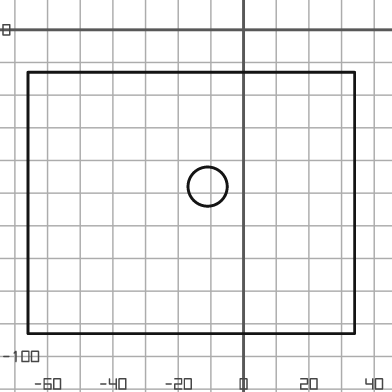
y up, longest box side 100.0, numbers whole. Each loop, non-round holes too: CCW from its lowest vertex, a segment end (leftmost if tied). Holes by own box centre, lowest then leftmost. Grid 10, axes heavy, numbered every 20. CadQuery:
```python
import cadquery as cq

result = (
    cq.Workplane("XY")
    .moveTo(-66.0, -93.0)
    .lineTo(34.0, -93.0)
    .lineTo(34.0, -13.0)
    .lineTo(-66.0, -13.0)
    .close()
    .moveTo(-11.0, -48.0)
    .circle(6.0)
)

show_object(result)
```